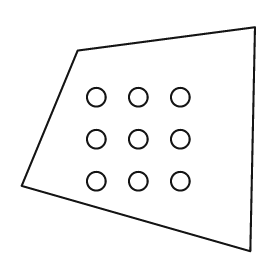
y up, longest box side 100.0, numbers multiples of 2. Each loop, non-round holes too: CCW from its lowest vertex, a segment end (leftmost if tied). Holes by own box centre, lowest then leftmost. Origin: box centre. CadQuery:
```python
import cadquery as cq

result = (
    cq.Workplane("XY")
    .moveTo(48.0, -48.0)
    .lineTo(50.0, 48.0)
    .lineTo(-26.0, 38.0)
    .lineTo(-50.0, -20.0)
    .close()
    .moveTo(-18.0, -18.0)
    .circle(4.0)
    .moveTo(0.0, -18.0)
    .circle(4.0)
    .moveTo(18.0, -18.0)
    .circle(4.0)
    .moveTo(-18.0, 0.0)
    .circle(4.0)
    .moveTo(0.0, 0.0)
    .circle(4.0)
    .moveTo(18.0, 0.0)
    .circle(4.0)
    .moveTo(-18.0, 18.0)
    .circle(4.0)
    .moveTo(0.0, 18.0)
    .circle(4.0)
    .moveTo(18.0, 18.0)
    .circle(4.0)
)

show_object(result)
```